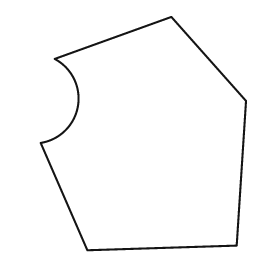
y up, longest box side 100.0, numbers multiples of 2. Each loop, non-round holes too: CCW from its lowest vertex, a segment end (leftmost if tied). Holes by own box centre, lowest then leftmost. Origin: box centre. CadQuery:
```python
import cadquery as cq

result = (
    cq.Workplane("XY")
    .moveTo(-24.0, -50.0)
    .lineTo(40.0, -48.0)
    .lineTo(44.0, 14.0)
    .lineTo(12.0, 50.0)
    .lineTo(-38.0, 32.0)
    .threePointArc((-28.0, 12.0), (-44.0, -4.0))
    .close()
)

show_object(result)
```